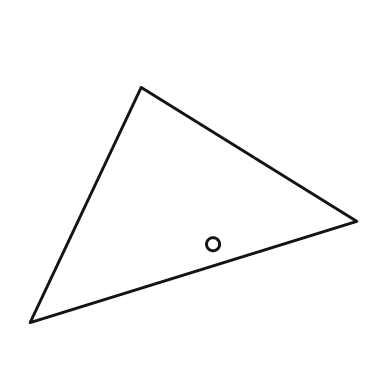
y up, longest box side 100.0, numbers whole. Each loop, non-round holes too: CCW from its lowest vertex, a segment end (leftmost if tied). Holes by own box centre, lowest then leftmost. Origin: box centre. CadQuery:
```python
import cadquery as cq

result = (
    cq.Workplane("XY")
    .moveTo(-50.0, -36.0)
    .lineTo(50.0, -5.0)
    .lineTo(-16.0, 36.0)
    .close()
    .moveTo(6.0, -12.0)
    .circle(2.0)
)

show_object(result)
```